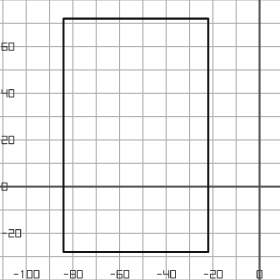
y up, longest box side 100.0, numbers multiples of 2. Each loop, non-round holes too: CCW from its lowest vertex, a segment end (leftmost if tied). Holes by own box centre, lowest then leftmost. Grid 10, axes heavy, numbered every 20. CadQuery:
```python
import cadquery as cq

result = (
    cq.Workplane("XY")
    .moveTo(-84.0, -28.0)
    .lineTo(-22.0, -28.0)
    .lineTo(-22.0, 72.0)
    .lineTo(-84.0, 72.0)
    .close()
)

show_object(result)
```